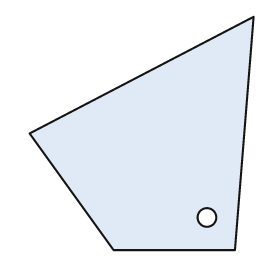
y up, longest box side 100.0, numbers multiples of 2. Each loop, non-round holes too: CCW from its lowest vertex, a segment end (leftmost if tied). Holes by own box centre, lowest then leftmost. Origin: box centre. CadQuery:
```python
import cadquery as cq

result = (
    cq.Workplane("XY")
    .moveTo(-12.0, -50.0)
    .lineTo(40.0, -50.0)
    .lineTo(48.0, 50.0)
    .lineTo(-48.0, 0.0)
    .close()
    .moveTo(28.0, -36.0)
    .circle(4.0)
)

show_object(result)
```